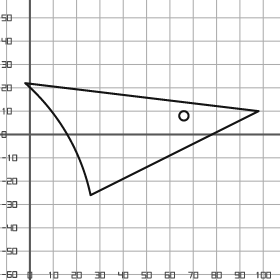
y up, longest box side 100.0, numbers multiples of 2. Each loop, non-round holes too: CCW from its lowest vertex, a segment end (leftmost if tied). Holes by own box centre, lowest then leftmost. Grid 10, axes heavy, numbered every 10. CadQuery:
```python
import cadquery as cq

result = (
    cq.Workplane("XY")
    .moveTo(26.0, -26.0)
    .lineTo(98.0, 10.0)
    .lineTo(-2.0, 22.0)
    .threePointArc((16.0, 0.0), (26.0, -26.0))
    .close()
    .moveTo(66.0, 8.0)
    .circle(2.0)
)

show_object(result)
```